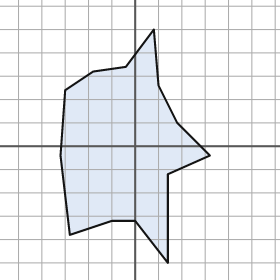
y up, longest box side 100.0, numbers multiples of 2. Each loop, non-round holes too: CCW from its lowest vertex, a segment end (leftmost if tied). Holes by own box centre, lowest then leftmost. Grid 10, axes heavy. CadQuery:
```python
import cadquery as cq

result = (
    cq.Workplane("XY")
    .moveTo(14.0, -50.0)
    .lineTo(14.0, -12.0)
    .lineTo(32.0, -4.0)
    .lineTo(18.0, 10.0)
    .lineTo(10.0, 26.0)
    .lineTo(8.0, 50.0)
    .lineTo(-4.0, 34.0)
    .lineTo(-18.0, 32.0)
    .lineTo(-30.0, 24.0)
    .lineTo(-32.0, -4.0)
    .lineTo(-28.0, -38.0)
    .lineTo(-10.0, -32.0)
    .lineTo(0.0, -32.0)
    .close()
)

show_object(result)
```